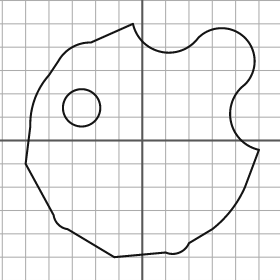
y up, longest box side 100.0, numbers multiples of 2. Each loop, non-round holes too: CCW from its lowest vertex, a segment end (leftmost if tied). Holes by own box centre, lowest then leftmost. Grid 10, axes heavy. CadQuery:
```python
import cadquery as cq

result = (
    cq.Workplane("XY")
    .moveTo(-12.0, -50.0)
    .lineTo(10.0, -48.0)
    .threePointArc((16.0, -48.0), (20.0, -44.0))
    .lineTo(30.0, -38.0)
    .threePointArc((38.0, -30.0), (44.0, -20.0))
    .lineTo(50.0, -4.0)
    .threePointArc((38.0, 8.0), (44.0, 24.0))
    .threePointArc((44.0, 44.0), (24.0, 44.0))
    .threePointArc((8.0, 38.0), (-4.0, 50.0))
    .lineTo(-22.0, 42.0)
    .threePointArc((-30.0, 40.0), (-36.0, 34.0))
    .lineTo(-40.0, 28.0)
    .threePointArc((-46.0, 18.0), (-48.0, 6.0))
    .lineTo(-50.0, -10.0)
    .lineTo(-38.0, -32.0)
    .threePointArc((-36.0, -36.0), (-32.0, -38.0))
    .close()
    .moveTo(-26.0, 14.0)
    .circle(8.0)
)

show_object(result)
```